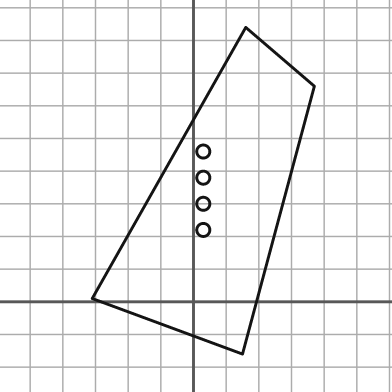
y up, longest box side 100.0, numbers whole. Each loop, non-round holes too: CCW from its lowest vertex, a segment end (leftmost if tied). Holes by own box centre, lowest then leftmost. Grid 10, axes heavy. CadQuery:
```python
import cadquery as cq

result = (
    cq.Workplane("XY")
    .moveTo(15.0, -16.0)
    .lineTo(37.0, 66.0)
    .lineTo(16.0, 84.0)
    .lineTo(-31.0, 1.0)
    .close()
    .moveTo(3.0, 22.0)
    .circle(2.0)
    .moveTo(3.0, 30.0)
    .circle(2.0)
    .moveTo(3.0, 38.0)
    .circle(2.0)
    .moveTo(3.0, 46.0)
    .circle(2.0)
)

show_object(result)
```